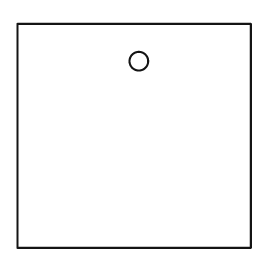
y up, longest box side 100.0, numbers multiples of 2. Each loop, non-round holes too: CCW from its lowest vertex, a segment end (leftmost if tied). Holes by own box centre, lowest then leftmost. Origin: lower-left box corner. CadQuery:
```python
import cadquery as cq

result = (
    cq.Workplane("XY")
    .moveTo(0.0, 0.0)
    .lineTo(100.0, 0.0)
    .lineTo(100.0, 96.0)
    .lineTo(0.0, 96.0)
    .close()
    .moveTo(52.0, 80.0)
    .circle(4.0)
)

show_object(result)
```